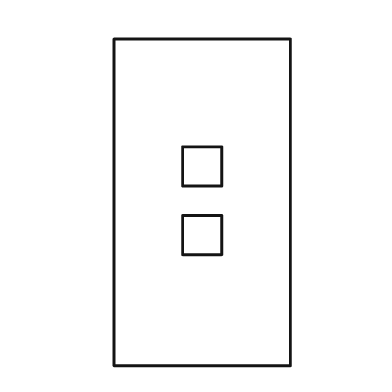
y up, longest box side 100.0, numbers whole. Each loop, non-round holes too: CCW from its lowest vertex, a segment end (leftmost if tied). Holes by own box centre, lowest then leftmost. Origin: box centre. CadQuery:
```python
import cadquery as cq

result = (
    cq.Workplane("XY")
    .moveTo(-27.0, -50.0)
    .lineTo(27.0, -50.0)
    .lineTo(27.0, 50.0)
    .lineTo(-27.0, 50.0)
    .close()
    .moveTo(-6.0, -16.0)
    .lineTo(6.0, -16.0)
    .lineTo(6.0, -4.0)
    .lineTo(-6.0, -4.0)
    .close()
    .moveTo(-6.0, 5.0)
    .lineTo(6.0, 5.0)
    .lineTo(6.0, 17.0)
    .lineTo(-6.0, 17.0)
    .close()
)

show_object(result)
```